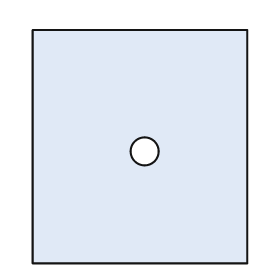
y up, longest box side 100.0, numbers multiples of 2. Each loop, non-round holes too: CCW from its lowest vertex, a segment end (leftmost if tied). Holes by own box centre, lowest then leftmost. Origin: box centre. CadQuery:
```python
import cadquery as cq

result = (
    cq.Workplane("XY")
    .moveTo(-46.0, -50.0)
    .lineTo(46.0, -50.0)
    .lineTo(46.0, 50.0)
    .lineTo(-46.0, 50.0)
    .close()
    .moveTo(2.0, -2.0)
    .circle(6.0)
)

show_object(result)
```